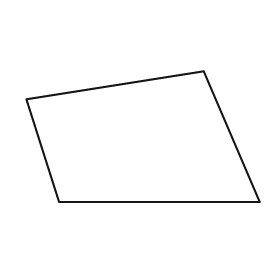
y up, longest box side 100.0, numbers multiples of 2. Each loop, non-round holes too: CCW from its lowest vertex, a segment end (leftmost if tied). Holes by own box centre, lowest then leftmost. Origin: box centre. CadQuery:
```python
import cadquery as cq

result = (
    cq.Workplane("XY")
    .moveTo(-36.0, -28.0)
    .lineTo(50.0, -28.0)
    .lineTo(26.0, 28.0)
    .lineTo(-50.0, 16.0)
    .close()
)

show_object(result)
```